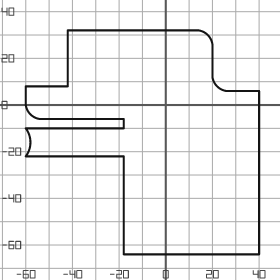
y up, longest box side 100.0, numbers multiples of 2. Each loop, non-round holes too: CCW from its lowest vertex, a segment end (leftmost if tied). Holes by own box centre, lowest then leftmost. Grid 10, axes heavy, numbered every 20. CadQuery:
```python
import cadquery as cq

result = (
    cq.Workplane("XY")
    .moveTo(-18.0, -64.0)
    .lineTo(40.0, -64.0)
    .lineTo(40.0, 6.0)
    .lineTo(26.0, 6.0)
    .threePointArc((22.0, 8.0), (20.0, 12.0))
    .lineTo(20.0, 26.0)
    .threePointArc((18.0, 30.0), (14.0, 32.0))
    .lineTo(-42.0, 32.0)
    .lineTo(-42.0, 8.0)
    .lineTo(-60.0, 8.0)
    .lineTo(-60.0, 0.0)
    .threePointArc((-58.0, -4.0), (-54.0, -6.0))
    .lineTo(-18.0, -6.0)
    .lineTo(-18.0, -10.0)
    .lineTo(-60.0, -10.0)
    .threePointArc((-58.0, -16.0), (-60.0, -22.0))
    .lineTo(-18.0, -22.0)
    .close()
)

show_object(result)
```